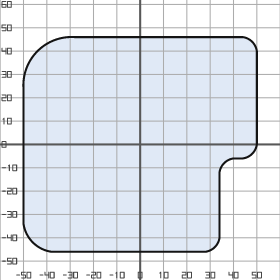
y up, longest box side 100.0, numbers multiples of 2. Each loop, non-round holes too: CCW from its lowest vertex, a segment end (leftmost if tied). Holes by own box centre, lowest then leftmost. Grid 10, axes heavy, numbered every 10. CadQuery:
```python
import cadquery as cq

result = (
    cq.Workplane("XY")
    .moveTo(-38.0, -46.0)
    .lineTo(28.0, -46.0)
    .threePointArc((32.0, -44.0), (34.0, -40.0))
    .lineTo(34.0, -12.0)
    .threePointArc((36.0, -8.0), (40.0, -6.0))
    .lineTo(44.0, -6.0)
    .threePointArc((48.0, -4.0), (50.0, 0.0))
    .lineTo(50.0, 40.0)
    .threePointArc((48.0, 44.0), (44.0, 46.0))
    .lineTo(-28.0, 46.0)
    .threePointArc((-44.0, 40.0), (-50.0, 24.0))
    .lineTo(-50.0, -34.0)
    .threePointArc((-46.0, -42.0), (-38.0, -46.0))
    .close()
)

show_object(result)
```